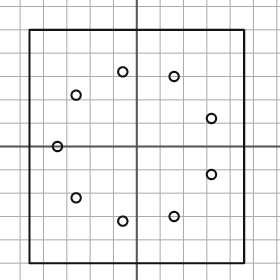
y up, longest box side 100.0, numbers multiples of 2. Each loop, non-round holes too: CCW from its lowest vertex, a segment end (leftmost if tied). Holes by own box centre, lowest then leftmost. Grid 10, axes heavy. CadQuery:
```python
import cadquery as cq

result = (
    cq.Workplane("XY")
    .moveTo(-46.0, -50.0)
    .lineTo(46.0, -50.0)
    .lineTo(46.0, 50.0)
    .lineTo(-46.0, 50.0)
    .close()
    .moveTo(-6.0, -32.0)
    .circle(2.0)
    .moveTo(16.0, -30.0)
    .circle(2.0)
    .moveTo(-26.0, -22.0)
    .circle(2.0)
    .moveTo(32.0, -12.0)
    .circle(2.0)
    .moveTo(-34.0, 0.0)
    .circle(2.0)
    .moveTo(32.0, 12.0)
    .circle(2.0)
    .moveTo(-26.0, 22.0)
    .circle(2.0)
    .moveTo(16.0, 30.0)
    .circle(2.0)
    .moveTo(-6.0, 32.0)
    .circle(2.0)
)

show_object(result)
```